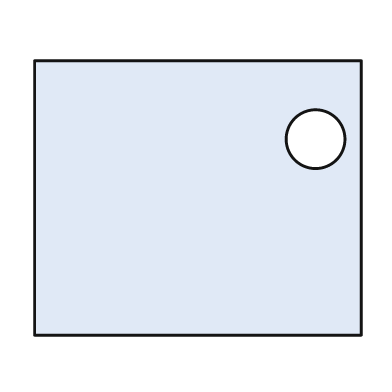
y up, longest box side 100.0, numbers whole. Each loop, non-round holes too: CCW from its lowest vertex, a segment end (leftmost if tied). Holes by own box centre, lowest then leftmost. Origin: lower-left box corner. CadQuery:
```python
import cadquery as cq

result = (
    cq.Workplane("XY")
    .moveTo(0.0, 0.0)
    .lineTo(100.0, 0.0)
    .lineTo(100.0, 84.0)
    .lineTo(0.0, 84.0)
    .close()
    .moveTo(86.0, 60.0)
    .circle(9.0)
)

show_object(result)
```